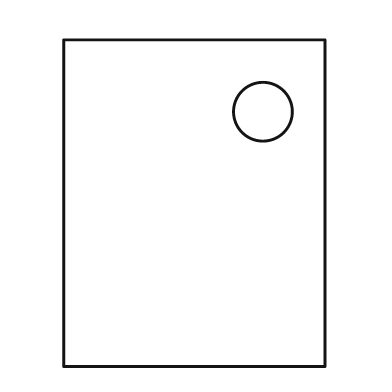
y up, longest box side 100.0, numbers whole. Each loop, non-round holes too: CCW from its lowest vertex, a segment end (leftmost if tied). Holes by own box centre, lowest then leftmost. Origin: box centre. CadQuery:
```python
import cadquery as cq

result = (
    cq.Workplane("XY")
    .moveTo(-40.0, -50.0)
    .lineTo(40.0, -50.0)
    .lineTo(40.0, 50.0)
    .lineTo(-40.0, 50.0)
    .close()
    .moveTo(21.0, 28.0)
    .circle(9.0)
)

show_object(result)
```